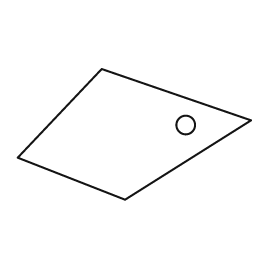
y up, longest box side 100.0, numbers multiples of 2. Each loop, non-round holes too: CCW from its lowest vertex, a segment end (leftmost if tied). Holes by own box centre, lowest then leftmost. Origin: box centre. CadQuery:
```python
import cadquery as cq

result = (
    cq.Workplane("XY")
    .moveTo(-4.0, -28.0)
    .lineTo(50.0, 6.0)
    .lineTo(-14.0, 28.0)
    .lineTo(-50.0, -10.0)
    .close()
    .moveTo(22.0, 4.0)
    .circle(4.0)
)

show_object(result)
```